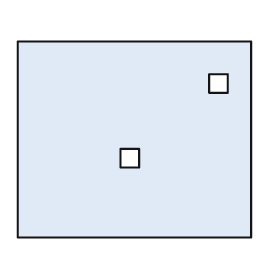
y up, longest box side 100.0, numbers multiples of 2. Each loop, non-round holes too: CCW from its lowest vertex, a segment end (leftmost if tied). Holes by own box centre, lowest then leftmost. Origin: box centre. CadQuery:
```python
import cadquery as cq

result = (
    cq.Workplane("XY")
    .moveTo(-50.0, -42.0)
    .lineTo(50.0, -42.0)
    .lineTo(50.0, 42.0)
    .lineTo(-50.0, 42.0)
    .close()
    .moveTo(-6.0, -12.0)
    .lineTo(2.0, -12.0)
    .lineTo(2.0, -4.0)
    .lineTo(-6.0, -4.0)
    .close()
    .moveTo(32.0, 20.0)
    .lineTo(40.0, 20.0)
    .lineTo(40.0, 28.0)
    .lineTo(32.0, 28.0)
    .close()
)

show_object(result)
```